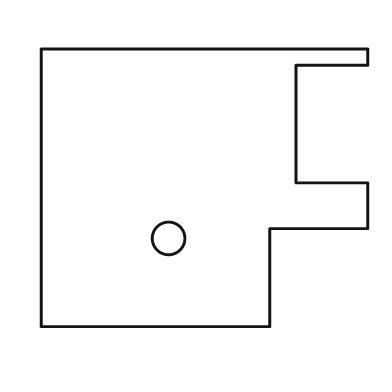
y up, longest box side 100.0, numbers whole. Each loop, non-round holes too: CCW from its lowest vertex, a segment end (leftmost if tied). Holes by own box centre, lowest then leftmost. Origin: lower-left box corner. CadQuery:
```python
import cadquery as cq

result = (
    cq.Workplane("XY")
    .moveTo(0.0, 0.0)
    .lineTo(70.0, 0.0)
    .lineTo(70.0, 30.0)
    .lineTo(100.0, 30.0)
    .lineTo(100.0, 44.0)
    .lineTo(78.0, 44.0)
    .lineTo(78.0, 80.0)
    .lineTo(100.0, 80.0)
    .lineTo(100.0, 85.0)
    .lineTo(0.0, 85.0)
    .close()
    .moveTo(39.0, 27.0)
    .circle(5.0)
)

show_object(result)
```